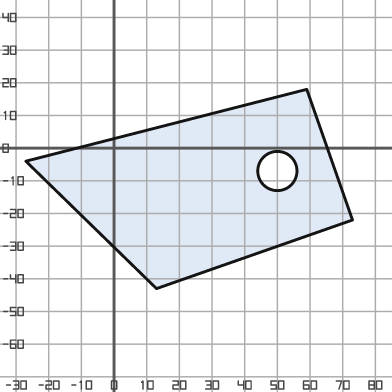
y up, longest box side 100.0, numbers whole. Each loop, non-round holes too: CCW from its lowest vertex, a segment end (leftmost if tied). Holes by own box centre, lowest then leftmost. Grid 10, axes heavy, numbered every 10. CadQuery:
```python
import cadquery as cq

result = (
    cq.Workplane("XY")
    .moveTo(13.0, -43.0)
    .lineTo(73.0, -22.0)
    .lineTo(59.0, 18.0)
    .lineTo(-27.0, -4.0)
    .close()
    .moveTo(50.0, -7.0)
    .circle(6.0)
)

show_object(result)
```